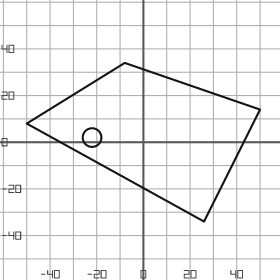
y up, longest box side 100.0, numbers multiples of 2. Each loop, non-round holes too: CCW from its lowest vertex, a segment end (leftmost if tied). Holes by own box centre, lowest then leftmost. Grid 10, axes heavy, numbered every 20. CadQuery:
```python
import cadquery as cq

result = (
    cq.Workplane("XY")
    .moveTo(26.0, -34.0)
    .lineTo(50.0, 14.0)
    .lineTo(-8.0, 34.0)
    .lineTo(-50.0, 8.0)
    .close()
    .moveTo(-22.0, 2.0)
    .circle(4.0)
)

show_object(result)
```